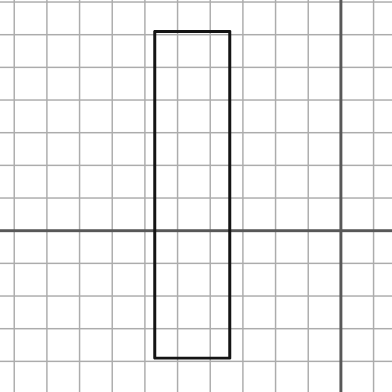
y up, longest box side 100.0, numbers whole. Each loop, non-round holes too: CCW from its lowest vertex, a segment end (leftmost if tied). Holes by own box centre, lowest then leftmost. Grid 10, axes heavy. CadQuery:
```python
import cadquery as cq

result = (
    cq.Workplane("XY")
    .moveTo(-57.0, -39.0)
    .lineTo(-34.0, -39.0)
    .lineTo(-34.0, 61.0)
    .lineTo(-57.0, 61.0)
    .close()
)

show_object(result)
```